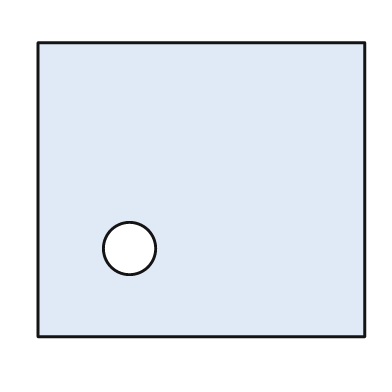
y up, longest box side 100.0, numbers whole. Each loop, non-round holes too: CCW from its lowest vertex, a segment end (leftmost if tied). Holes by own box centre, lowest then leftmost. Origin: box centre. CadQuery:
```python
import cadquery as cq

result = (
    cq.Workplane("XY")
    .moveTo(-50.0, -45.0)
    .lineTo(50.0, -45.0)
    .lineTo(50.0, 45.0)
    .lineTo(-50.0, 45.0)
    .close()
    .moveTo(-22.0, -18.0)
    .circle(8.0)
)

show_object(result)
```